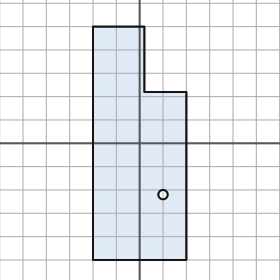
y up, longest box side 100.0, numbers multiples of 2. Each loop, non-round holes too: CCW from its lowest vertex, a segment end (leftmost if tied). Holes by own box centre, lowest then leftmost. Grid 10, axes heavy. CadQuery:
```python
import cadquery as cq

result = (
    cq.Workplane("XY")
    .moveTo(-20.0, -50.0)
    .lineTo(20.0, -50.0)
    .lineTo(20.0, 22.0)
    .lineTo(2.0, 22.0)
    .lineTo(2.0, 50.0)
    .lineTo(-20.0, 50.0)
    .close()
    .moveTo(10.0, -22.0)
    .circle(2.0)
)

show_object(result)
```